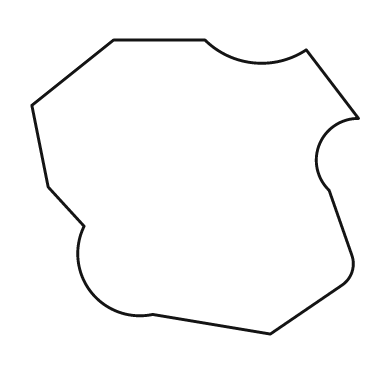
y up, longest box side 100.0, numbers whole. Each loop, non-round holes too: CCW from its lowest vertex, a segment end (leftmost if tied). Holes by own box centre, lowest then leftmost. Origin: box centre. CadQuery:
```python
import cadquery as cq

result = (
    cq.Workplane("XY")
    .moveTo(23.0, -45.0)
    .lineTo(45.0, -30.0)
    .threePointArc((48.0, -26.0), (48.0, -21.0))
    .lineTo(41.0, -1.0)
    .threePointArc((38.0, 13.0), (50.0, 21.0))
    .lineTo(34.0, 42.0)
    .threePointArc((18.0, 38.0), (3.0, 45.0))
    .lineTo(-25.0, 45.0)
    .lineTo(-50.0, 25.0)
    .lineTo(-45.0, 0.0)
    .lineTo(-34.0, -12.0)
    .threePointArc((-32.0, -32.0), (-13.0, -39.0))
    .close()
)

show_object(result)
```